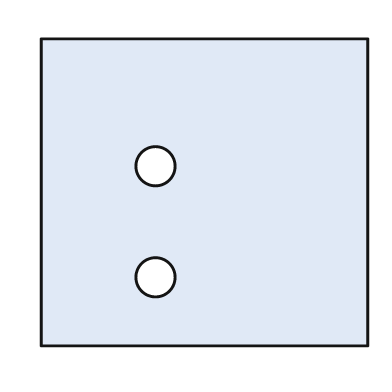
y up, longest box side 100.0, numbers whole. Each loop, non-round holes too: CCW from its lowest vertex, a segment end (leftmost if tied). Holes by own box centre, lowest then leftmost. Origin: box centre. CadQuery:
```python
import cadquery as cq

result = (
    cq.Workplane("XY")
    .moveTo(-50.0, -47.0)
    .lineTo(50.0, -47.0)
    .lineTo(50.0, 47.0)
    .lineTo(-50.0, 47.0)
    .close()
    .moveTo(-15.0, -26.0)
    .circle(6.0)
    .moveTo(-15.0, 8.0)
    .circle(6.0)
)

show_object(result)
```